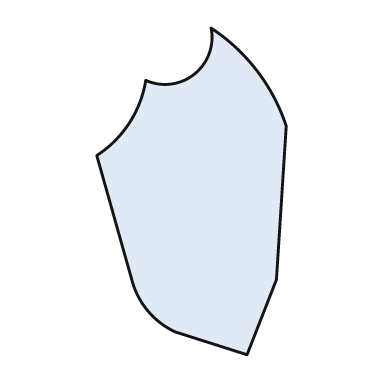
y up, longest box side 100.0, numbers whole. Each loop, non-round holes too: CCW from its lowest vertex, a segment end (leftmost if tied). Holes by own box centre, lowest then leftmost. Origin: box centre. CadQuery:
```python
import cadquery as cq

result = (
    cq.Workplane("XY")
    .moveTo(17.0, -50.0)
    .lineTo(26.0, -27.0)
    .lineTo(29.0, 20.0)
    .threePointArc((20.0, 37.0), (6.0, 50.0))
    .threePointArc((1.0, 36.0), (-14.0, 34.0))
    .threePointArc((-19.0, 21.0), (-29.0, 11.0))
    .lineTo(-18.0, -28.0)
    .threePointArc((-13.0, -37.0), (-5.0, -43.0))
    .close()
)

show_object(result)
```